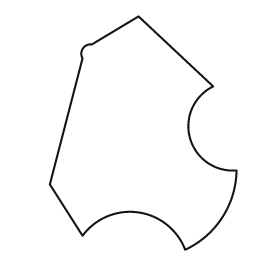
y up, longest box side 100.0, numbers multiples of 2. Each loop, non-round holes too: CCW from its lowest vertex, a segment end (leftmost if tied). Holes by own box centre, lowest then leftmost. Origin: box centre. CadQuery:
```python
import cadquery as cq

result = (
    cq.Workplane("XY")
    .moveTo(18.0, -50.0)
    .threePointArc((34.0, -36.0), (40.0, -16.0))
    .threePointArc((20.0, -2.0), (30.0, 20.0))
    .lineTo(-2.0, 50.0)
    .lineTo(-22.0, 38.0)
    .threePointArc((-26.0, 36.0), (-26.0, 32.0))
    .lineTo(-40.0, -22.0)
    .lineTo(-26.0, -44.0)
    .threePointArc((-2.0, -34.0), (18.0, -50.0))
    .close()
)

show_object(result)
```